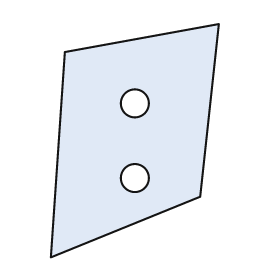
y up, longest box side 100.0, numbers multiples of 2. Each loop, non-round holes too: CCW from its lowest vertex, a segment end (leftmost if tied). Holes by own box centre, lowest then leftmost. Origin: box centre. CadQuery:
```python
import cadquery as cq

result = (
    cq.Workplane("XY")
    .moveTo(-36.0, -50.0)
    .lineTo(28.0, -24.0)
    .lineTo(36.0, 50.0)
    .lineTo(-30.0, 38.0)
    .close()
    .moveTo(0.0, -16.0)
    .circle(6.0)
    .moveTo(0.0, 16.0)
    .circle(6.0)
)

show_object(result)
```